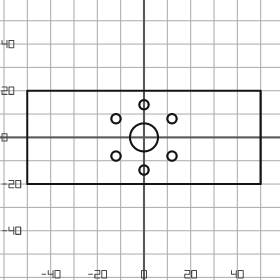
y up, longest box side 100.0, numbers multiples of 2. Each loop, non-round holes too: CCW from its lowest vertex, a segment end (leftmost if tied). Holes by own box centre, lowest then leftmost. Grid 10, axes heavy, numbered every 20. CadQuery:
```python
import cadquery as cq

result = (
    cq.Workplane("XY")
    .moveTo(-50.0, -20.0)
    .lineTo(50.0, -20.0)
    .lineTo(50.0, 20.0)
    .lineTo(-50.0, 20.0)
    .close()
    .moveTo(0.0, -14.0)
    .circle(2.0)
    .moveTo(-12.0, -8.0)
    .circle(2.0)
    .moveTo(12.0, -8.0)
    .circle(2.0)
    .moveTo(0.0, 0.0)
    .circle(6.0)
    .moveTo(-12.0, 8.0)
    .circle(2.0)
    .moveTo(12.0, 8.0)
    .circle(2.0)
    .moveTo(0.0, 14.0)
    .circle(2.0)
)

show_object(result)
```